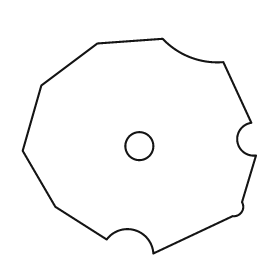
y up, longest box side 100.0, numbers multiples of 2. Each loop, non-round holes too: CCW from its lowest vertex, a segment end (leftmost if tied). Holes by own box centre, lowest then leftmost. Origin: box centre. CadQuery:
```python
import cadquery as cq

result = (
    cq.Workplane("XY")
    .moveTo(6.0, -46.0)
    .lineTo(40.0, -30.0)
    .threePointArc((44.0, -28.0), (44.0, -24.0))
    .lineTo(50.0, -4.0)
    .threePointArc((42.0, 2.0), (48.0, 10.0))
    .lineTo(36.0, 36.0)
    .threePointArc((22.0, 38.0), (10.0, 46.0))
    .lineTo(-18.0, 44.0)
    .lineTo(-42.0, 26.0)
    .lineTo(-50.0, -2.0)
    .lineTo(-36.0, -26.0)
    .lineTo(-14.0, -40.0)
    .threePointArc((-2.0, -36.0), (6.0, -46.0))
    .close()
    .moveTo(0.0, 0.0)
    .circle(6.0)
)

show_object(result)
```